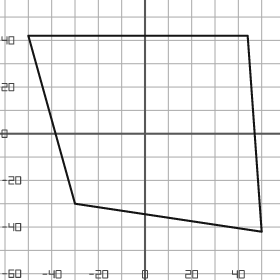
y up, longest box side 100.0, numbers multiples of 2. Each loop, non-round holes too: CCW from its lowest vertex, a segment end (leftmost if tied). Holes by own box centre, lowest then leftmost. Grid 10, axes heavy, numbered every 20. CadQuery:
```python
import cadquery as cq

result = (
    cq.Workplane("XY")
    .moveTo(50.0, -42.0)
    .lineTo(44.0, 42.0)
    .lineTo(-50.0, 42.0)
    .lineTo(-30.0, -30.0)
    .close()
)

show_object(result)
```